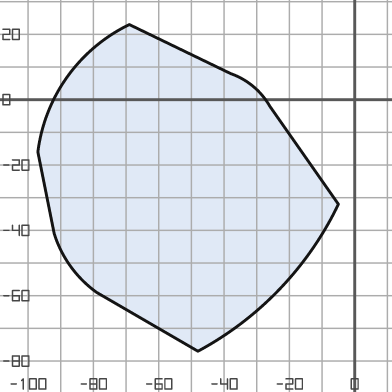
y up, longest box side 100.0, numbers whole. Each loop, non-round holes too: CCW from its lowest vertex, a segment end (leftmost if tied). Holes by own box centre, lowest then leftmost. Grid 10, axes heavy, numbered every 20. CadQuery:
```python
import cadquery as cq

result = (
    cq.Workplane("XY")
    .moveTo(-48.0, -77.0)
    .threePointArc((-23.0, -58.0), (-5.0, -32.0))
    .lineTo(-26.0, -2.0)
    .threePointArc((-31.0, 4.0), (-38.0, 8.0))
    .lineTo(-69.0, 23.0)
    .threePointArc((-88.0, 7.0), (-97.0, -16.0))
    .lineTo(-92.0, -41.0)
    .threePointArc((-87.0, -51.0), (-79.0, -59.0))
    .close()
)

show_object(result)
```